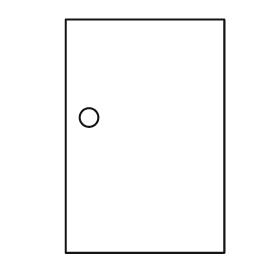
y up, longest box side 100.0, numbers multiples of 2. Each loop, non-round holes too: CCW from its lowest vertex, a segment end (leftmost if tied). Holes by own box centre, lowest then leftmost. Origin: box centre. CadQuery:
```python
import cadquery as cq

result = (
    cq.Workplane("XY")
    .moveTo(-34.0, -50.0)
    .lineTo(34.0, -50.0)
    .lineTo(34.0, 50.0)
    .lineTo(-34.0, 50.0)
    .close()
    .moveTo(-24.0, 8.0)
    .circle(4.0)
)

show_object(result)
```